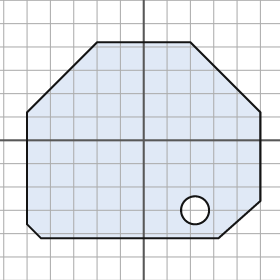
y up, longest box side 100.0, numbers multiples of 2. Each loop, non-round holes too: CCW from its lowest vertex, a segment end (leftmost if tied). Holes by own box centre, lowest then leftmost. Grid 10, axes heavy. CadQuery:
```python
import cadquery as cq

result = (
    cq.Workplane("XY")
    .moveTo(-44.0, -42.0)
    .lineTo(32.0, -42.0)
    .lineTo(50.0, -26.0)
    .lineTo(50.0, 12.0)
    .lineTo(20.0, 42.0)
    .lineTo(-20.0, 42.0)
    .lineTo(-50.0, 12.0)
    .lineTo(-50.0, -36.0)
    .close()
    .moveTo(22.0, -30.0)
    .circle(6.0)
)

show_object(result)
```